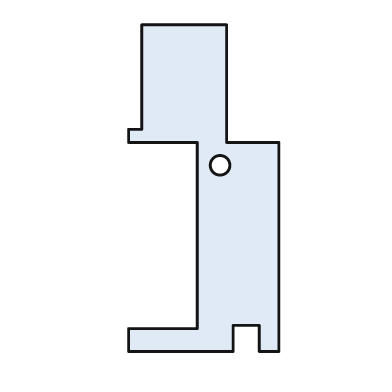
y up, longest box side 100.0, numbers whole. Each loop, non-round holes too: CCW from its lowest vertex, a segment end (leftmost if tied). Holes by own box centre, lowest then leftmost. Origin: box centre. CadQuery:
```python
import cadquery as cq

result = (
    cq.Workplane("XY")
    .moveTo(-23.0, -50.0)
    .lineTo(9.0, -50.0)
    .lineTo(9.0, -42.0)
    .lineTo(17.0, -42.0)
    .lineTo(17.0, -50.0)
    .lineTo(23.0, -50.0)
    .lineTo(23.0, 14.0)
    .lineTo(7.0, 14.0)
    .lineTo(7.0, 50.0)
    .lineTo(-19.0, 50.0)
    .lineTo(-19.0, 18.0)
    .lineTo(-23.0, 18.0)
    .lineTo(-23.0, 14.0)
    .lineTo(-2.0, 14.0)
    .lineTo(-2.0, -43.0)
    .lineTo(-23.0, -43.0)
    .close()
    .moveTo(5.0, 7.0)
    .circle(3.0)
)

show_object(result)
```